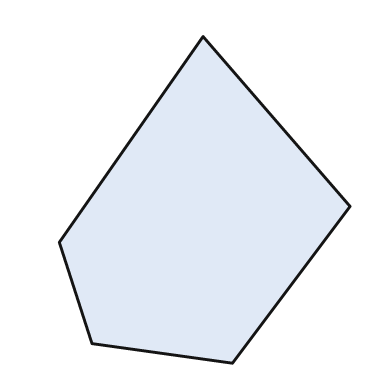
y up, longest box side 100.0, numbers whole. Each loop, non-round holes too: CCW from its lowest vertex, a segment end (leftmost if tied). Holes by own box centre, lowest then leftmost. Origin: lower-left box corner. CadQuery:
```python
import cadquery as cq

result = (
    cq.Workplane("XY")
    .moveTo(53.0, 0.0)
    .lineTo(89.0, 48.0)
    .lineTo(44.0, 100.0)
    .lineTo(0.0, 37.0)
    .lineTo(10.0, 6.0)
    .close()
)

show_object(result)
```